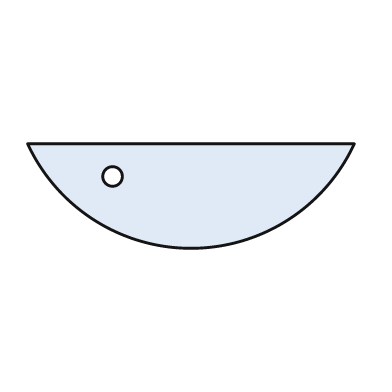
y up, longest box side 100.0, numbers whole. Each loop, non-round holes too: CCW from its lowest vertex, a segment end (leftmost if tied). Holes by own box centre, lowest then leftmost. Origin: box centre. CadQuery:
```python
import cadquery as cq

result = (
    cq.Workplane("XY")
    .moveTo(-50.0, 16.0)
    .threePointArc((0.0, -16.0), (50.0, 16.0))
    .close()
    .moveTo(-24.0, 6.0)
    .circle(3.0)
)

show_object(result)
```